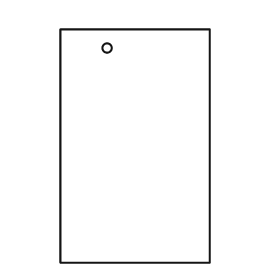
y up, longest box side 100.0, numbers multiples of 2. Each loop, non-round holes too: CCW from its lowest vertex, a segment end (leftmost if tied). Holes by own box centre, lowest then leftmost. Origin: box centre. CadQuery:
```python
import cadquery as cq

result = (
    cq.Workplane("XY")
    .moveTo(-32.0, -50.0)
    .lineTo(32.0, -50.0)
    .lineTo(32.0, 50.0)
    .lineTo(-32.0, 50.0)
    .close()
    .moveTo(-12.0, 42.0)
    .circle(2.0)
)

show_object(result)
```